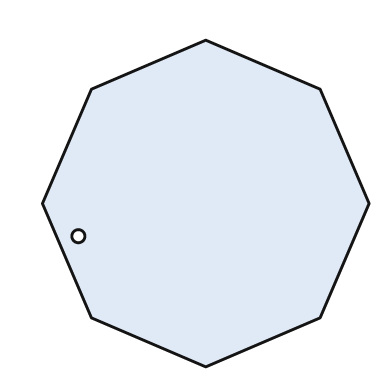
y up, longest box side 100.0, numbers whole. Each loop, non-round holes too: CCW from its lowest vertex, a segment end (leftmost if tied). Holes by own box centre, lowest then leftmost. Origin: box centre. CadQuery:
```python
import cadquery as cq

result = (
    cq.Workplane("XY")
    .moveTo(0.0, -50.0)
    .lineTo(35.0, -35.0)
    .lineTo(50.0, 0.0)
    .lineTo(35.0, 35.0)
    .lineTo(0.0, 50.0)
    .lineTo(-35.0, 35.0)
    .lineTo(-50.0, 0.0)
    .lineTo(-35.0, -35.0)
    .close()
    .moveTo(-39.0, -10.0)
    .circle(2.0)
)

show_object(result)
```